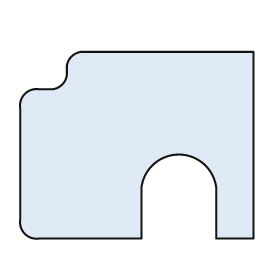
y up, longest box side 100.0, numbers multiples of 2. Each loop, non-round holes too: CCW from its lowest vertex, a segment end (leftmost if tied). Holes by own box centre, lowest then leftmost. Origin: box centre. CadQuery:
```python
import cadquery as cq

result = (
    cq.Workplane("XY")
    .moveTo(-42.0, -40.0)
    .lineTo(2.0, -40.0)
    .lineTo(2.0, -18.0)
    .threePointArc((18.0, -4.0), (34.0, -18.0))
    .lineTo(34.0, -40.0)
    .lineTo(50.0, -40.0)
    .lineTo(50.0, 40.0)
    .lineTo(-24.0, 40.0)
    .threePointArc((-28.0, 38.0), (-30.0, 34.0))
    .lineTo(-30.0, 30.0)
    .threePointArc((-32.0, 26.0), (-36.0, 24.0))
    .lineTo(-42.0, 24.0)
    .threePointArc((-48.0, 22.0), (-50.0, 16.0))
    .lineTo(-50.0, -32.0)
    .threePointArc((-48.0, -38.0), (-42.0, -40.0))
    .close()
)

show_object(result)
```